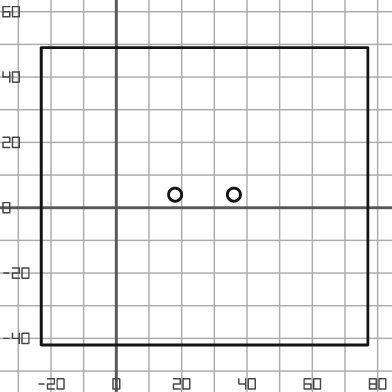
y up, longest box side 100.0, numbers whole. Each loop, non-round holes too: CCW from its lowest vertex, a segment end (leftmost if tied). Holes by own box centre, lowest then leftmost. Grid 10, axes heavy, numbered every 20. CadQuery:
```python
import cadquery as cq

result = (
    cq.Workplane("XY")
    .moveTo(-23.0, -42.0)
    .lineTo(77.0, -42.0)
    .lineTo(77.0, 49.0)
    .lineTo(-23.0, 49.0)
    .close()
    .moveTo(18.0, 4.0)
    .circle(2.0)
    .moveTo(36.0, 4.0)
    .circle(2.0)
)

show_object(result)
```